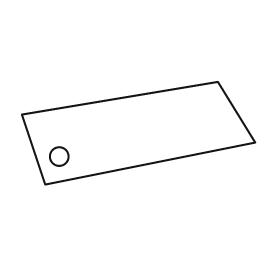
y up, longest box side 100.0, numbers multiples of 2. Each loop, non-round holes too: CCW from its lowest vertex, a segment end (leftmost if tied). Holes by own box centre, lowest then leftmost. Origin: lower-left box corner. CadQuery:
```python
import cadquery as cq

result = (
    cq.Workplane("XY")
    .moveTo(10.0, 0.0)
    .lineTo(100.0, 18.0)
    .lineTo(84.0, 44.0)
    .lineTo(0.0, 30.0)
    .close()
    .moveTo(16.0, 12.0)
    .circle(4.0)
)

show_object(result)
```